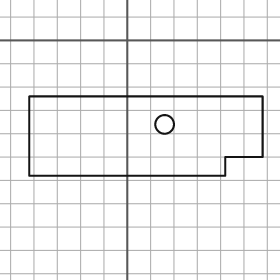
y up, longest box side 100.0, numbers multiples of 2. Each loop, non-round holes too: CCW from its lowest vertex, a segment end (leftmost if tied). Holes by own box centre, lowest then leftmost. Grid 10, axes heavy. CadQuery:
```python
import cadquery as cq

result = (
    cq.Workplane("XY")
    .moveTo(-42.0, -58.0)
    .lineTo(42.0, -58.0)
    .lineTo(42.0, -50.0)
    .lineTo(58.0, -50.0)
    .lineTo(58.0, -24.0)
    .lineTo(-42.0, -24.0)
    .close()
    .moveTo(16.0, -36.0)
    .circle(4.0)
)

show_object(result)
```